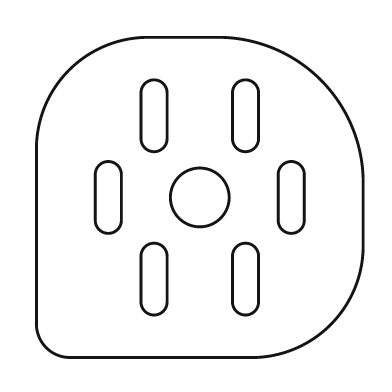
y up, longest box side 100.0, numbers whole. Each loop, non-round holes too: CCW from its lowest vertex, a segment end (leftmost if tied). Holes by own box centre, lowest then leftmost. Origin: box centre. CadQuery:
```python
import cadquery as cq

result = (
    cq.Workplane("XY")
    .moveTo(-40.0, -49.0)
    .lineTo(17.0, -49.0)
    .threePointArc((40.0, -39.0), (50.0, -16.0))
    .lineTo(50.0, 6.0)
    .threePointArc((37.0, 36.0), (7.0, 49.0))
    .lineTo(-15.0, 49.0)
    .threePointArc((-40.0, 39.0), (-50.0, 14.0))
    .lineTo(-50.0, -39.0)
    .threePointArc((-47.0, -46.0), (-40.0, -49.0))
    .close()
    .moveTo(-18.0, -32.0)
    .threePointArc((-14.0, -36.0), (-10.0, -32.0))
    .lineTo(-10.0, -18.0)
    .threePointArc((-14.0, -14.0), (-18.0, -18.0))
    .close()
    .moveTo(10.0, -32.0)
    .threePointArc((14.0, -36.0), (18.0, -32.0))
    .lineTo(18.0, -18.0)
    .threePointArc((14.0, -14.0), (10.0, -18.0))
    .close()
    .moveTo(-32.0, -7.0)
    .threePointArc((-28.0, -11.0), (-24.0, -7.0))
    .lineTo(-24.0, 7.0)
    .threePointArc((-28.0, 11.0), (-32.0, 7.0))
    .close()
    .moveTo(0.0, 0.0)
    .circle(9.0)
    .moveTo(24.0, -7.0)
    .threePointArc((28.0, -11.0), (32.0, -7.0))
    .lineTo(32.0, 7.0)
    .threePointArc((28.0, 11.0), (24.0, 7.0))
    .close()
    .moveTo(-18.0, 18.0)
    .threePointArc((-14.0, 14.0), (-10.0, 18.0))
    .lineTo(-10.0, 32.0)
    .threePointArc((-14.0, 36.0), (-18.0, 32.0))
    .close()
    .moveTo(10.0, 18.0)
    .threePointArc((14.0, 14.0), (18.0, 18.0))
    .lineTo(18.0, 32.0)
    .threePointArc((14.0, 36.0), (10.0, 32.0))
    .close()
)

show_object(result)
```